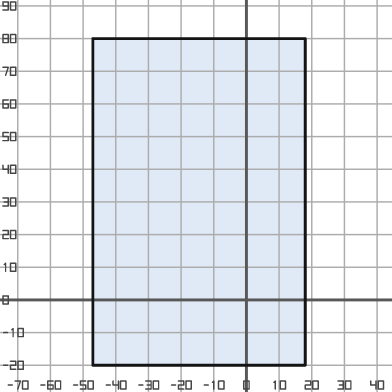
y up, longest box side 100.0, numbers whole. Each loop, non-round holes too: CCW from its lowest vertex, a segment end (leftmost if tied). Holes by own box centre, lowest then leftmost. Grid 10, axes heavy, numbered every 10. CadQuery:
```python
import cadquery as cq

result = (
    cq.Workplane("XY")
    .moveTo(-47.0, -20.0)
    .lineTo(18.0, -20.0)
    .lineTo(18.0, 80.0)
    .lineTo(-47.0, 80.0)
    .close()
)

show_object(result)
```